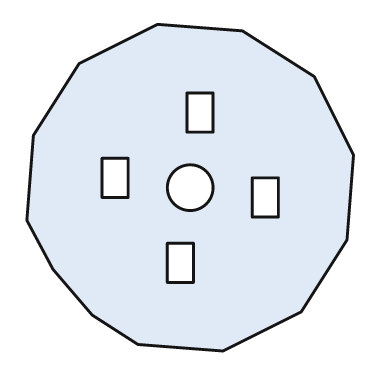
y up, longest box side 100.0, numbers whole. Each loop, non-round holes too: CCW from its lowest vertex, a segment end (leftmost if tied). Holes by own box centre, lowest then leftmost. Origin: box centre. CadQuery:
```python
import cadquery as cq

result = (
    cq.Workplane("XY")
    .moveTo(10.0, -50.0)
    .lineTo(34.0, -38.0)
    .lineTo(48.0, -16.0)
    .lineTo(50.0, 10.0)
    .lineTo(38.0, 34.0)
    .lineTo(16.0, 48.0)
    .lineTo(-10.0, 50.0)
    .lineTo(-34.0, 38.0)
    .lineTo(-48.0, 16.0)
    .lineTo(-50.0, -10.0)
    .lineTo(-42.0, -25.0)
    .lineTo(-30.0, -39.0)
    .lineTo(-16.0, -48.0)
    .close()
    .moveTo(-7.0, -29.0)
    .lineTo(1.0, -29.0)
    .lineTo(1.0, -17.0)
    .lineTo(-7.0, -17.0)
    .close()
    .moveTo(19.0, -9.0)
    .lineTo(27.0, -9.0)
    .lineTo(27.0, 3.0)
    .lineTo(19.0, 3.0)
    .close()
    .moveTo(0.0, 0.0)
    .circle(7.0)
    .moveTo(-27.0, -3.0)
    .lineTo(-19.0, -3.0)
    .lineTo(-19.0, 9.0)
    .lineTo(-27.0, 9.0)
    .close()
    .moveTo(-1.0, 17.0)
    .lineTo(7.0, 17.0)
    .lineTo(7.0, 29.0)
    .lineTo(-1.0, 29.0)
    .close()
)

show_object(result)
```